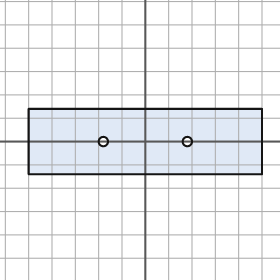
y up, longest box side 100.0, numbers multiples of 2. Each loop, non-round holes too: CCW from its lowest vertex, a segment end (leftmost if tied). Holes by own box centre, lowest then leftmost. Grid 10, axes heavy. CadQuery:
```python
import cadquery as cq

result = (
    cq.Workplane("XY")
    .moveTo(-50.0, -14.0)
    .lineTo(50.0, -14.0)
    .lineTo(50.0, 14.0)
    .lineTo(-50.0, 14.0)
    .close()
    .moveTo(-18.0, 0.0)
    .circle(2.0)
    .moveTo(18.0, 0.0)
    .circle(2.0)
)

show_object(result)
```